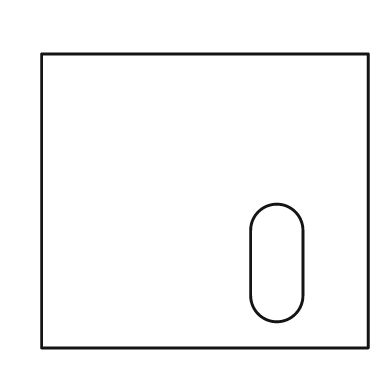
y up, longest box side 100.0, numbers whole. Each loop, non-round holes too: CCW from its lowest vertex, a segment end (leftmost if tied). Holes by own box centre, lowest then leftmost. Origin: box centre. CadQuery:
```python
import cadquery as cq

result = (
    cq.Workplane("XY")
    .moveTo(-50.0, -45.0)
    .lineTo(50.0, -45.0)
    .lineTo(50.0, 45.0)
    .lineTo(-50.0, 45.0)
    .close()
    .moveTo(14.0, -29.0)
    .threePointArc((22.0, -37.0), (30.0, -29.0))
    .lineTo(30.0, -9.0)
    .threePointArc((22.0, -1.0), (14.0, -9.0))
    .close()
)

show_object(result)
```